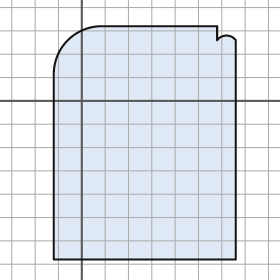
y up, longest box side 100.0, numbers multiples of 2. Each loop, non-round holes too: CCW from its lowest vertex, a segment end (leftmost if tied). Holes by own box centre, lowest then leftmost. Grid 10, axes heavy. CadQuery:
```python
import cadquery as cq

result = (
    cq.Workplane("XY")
    .moveTo(-12.0, -68.0)
    .lineTo(66.0, -68.0)
    .lineTo(66.0, 26.0)
    .threePointArc((62.0, 28.0), (58.0, 26.0))
    .lineTo(58.0, 32.0)
    .lineTo(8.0, 32.0)
    .threePointArc((-6.0, 26.0), (-12.0, 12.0))
    .close()
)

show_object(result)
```